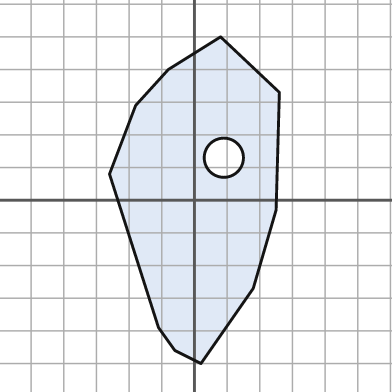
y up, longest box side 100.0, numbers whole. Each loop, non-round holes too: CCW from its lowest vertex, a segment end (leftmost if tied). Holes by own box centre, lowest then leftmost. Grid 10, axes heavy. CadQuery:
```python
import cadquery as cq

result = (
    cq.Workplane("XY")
    .moveTo(2.0, -50.0)
    .lineTo(18.0, -27.0)
    .lineTo(25.0, -3.0)
    .lineTo(26.0, 33.0)
    .lineTo(8.0, 50.0)
    .lineTo(-8.0, 40.0)
    .lineTo(-18.0, 29.0)
    .lineTo(-26.0, 8.0)
    .lineTo(-11.0, -39.0)
    .lineTo(-6.0, -46.0)
    .close()
    .moveTo(9.0, 13.0)
    .circle(6.0)
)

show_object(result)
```